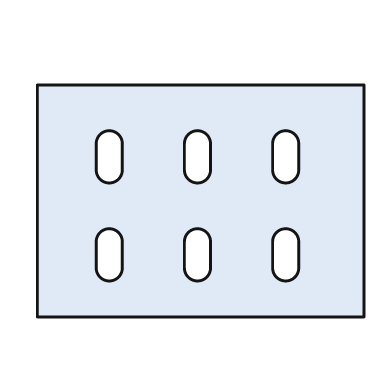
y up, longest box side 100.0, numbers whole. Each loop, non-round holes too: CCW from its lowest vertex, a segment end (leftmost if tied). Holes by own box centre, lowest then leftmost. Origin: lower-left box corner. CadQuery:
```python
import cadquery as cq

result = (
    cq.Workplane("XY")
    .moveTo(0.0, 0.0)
    .lineTo(100.0, 0.0)
    .lineTo(100.0, 71.0)
    .lineTo(0.0, 71.0)
    .close()
    .moveTo(18.0, 15.0)
    .threePointArc((22.0, 11.0), (26.0, 15.0))
    .lineTo(26.0, 23.0)
    .threePointArc((22.0, 27.0), (18.0, 23.0))
    .close()
    .moveTo(45.0, 15.0)
    .threePointArc((49.0, 11.0), (53.0, 15.0))
    .lineTo(53.0, 23.0)
    .threePointArc((49.0, 27.0), (45.0, 23.0))
    .close()
    .moveTo(72.0, 15.0)
    .threePointArc((76.0, 11.0), (80.0, 15.0))
    .lineTo(80.0, 23.0)
    .threePointArc((76.0, 27.0), (72.0, 23.0))
    .close()
    .moveTo(18.0, 45.0)
    .threePointArc((22.0, 41.0), (26.0, 45.0))
    .lineTo(26.0, 53.0)
    .threePointArc((22.0, 57.0), (18.0, 53.0))
    .close()
    .moveTo(45.0, 45.0)
    .threePointArc((49.0, 41.0), (53.0, 45.0))
    .lineTo(53.0, 53.0)
    .threePointArc((49.0, 57.0), (45.0, 53.0))
    .close()
    .moveTo(72.0, 45.0)
    .threePointArc((76.0, 41.0), (80.0, 45.0))
    .lineTo(80.0, 53.0)
    .threePointArc((76.0, 57.0), (72.0, 53.0))
    .close()
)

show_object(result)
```